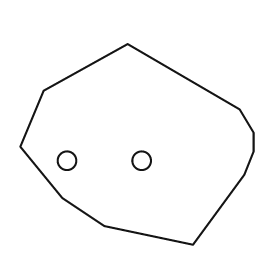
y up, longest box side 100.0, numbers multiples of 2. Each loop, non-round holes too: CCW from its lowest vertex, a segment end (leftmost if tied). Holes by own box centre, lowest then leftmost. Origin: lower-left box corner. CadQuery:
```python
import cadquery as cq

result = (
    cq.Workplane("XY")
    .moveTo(74.0, 0.0)
    .lineTo(96.0, 30.0)
    .lineTo(100.0, 40.0)
    .lineTo(100.0, 48.0)
    .lineTo(94.0, 58.0)
    .lineTo(46.0, 86.0)
    .lineTo(10.0, 66.0)
    .lineTo(0.0, 42.0)
    .lineTo(18.0, 20.0)
    .lineTo(36.0, 8.0)
    .close()
    .moveTo(20.0, 36.0)
    .circle(4.0)
    .moveTo(52.0, 36.0)
    .circle(4.0)
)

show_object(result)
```